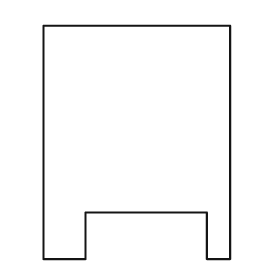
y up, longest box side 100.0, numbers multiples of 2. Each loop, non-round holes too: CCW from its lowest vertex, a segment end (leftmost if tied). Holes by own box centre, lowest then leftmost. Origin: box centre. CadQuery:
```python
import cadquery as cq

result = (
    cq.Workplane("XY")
    .moveTo(-40.0, -50.0)
    .lineTo(-22.0, -50.0)
    .lineTo(-22.0, -30.0)
    .lineTo(30.0, -30.0)
    .lineTo(30.0, -50.0)
    .lineTo(40.0, -50.0)
    .lineTo(40.0, 50.0)
    .lineTo(-40.0, 50.0)
    .close()
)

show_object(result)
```